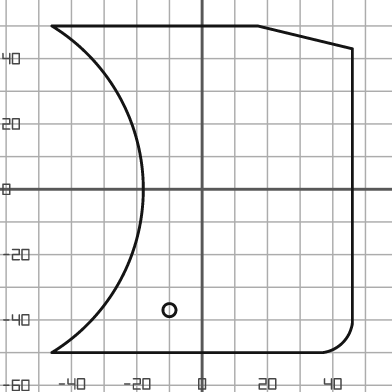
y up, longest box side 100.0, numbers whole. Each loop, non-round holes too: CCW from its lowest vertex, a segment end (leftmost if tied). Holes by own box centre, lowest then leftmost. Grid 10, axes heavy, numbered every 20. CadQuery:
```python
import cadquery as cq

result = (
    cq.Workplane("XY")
    .moveTo(-46.0, -50.0)
    .lineTo(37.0, -50.0)
    .threePointArc((43.0, -47.0), (46.0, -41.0))
    .lineTo(46.0, 43.0)
    .lineTo(17.0, 50.0)
    .lineTo(-46.0, 50.0)
    .threePointArc((-18.0, 0.0), (-46.0, -50.0))
    .close()
    .moveTo(-10.0, -37.0)
    .circle(2.0)
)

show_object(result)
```